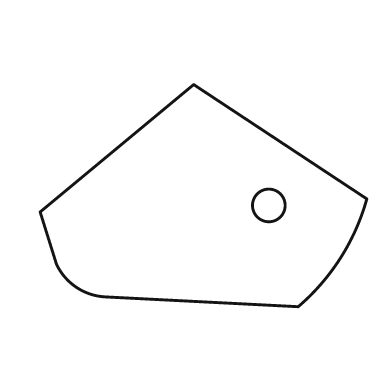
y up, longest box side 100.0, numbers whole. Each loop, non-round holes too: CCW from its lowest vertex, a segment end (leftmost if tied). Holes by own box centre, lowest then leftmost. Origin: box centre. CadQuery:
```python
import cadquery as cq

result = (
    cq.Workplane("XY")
    .moveTo(29.0, -34.0)
    .threePointArc((42.0, -19.0), (50.0, -1.0))
    .lineTo(-3.0, 34.0)
    .lineTo(-50.0, -5.0)
    .lineTo(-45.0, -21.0)
    .threePointArc((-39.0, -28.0), (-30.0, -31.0))
    .close()
    .moveTo(20.0, -3.0)
    .circle(5.0)
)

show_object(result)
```